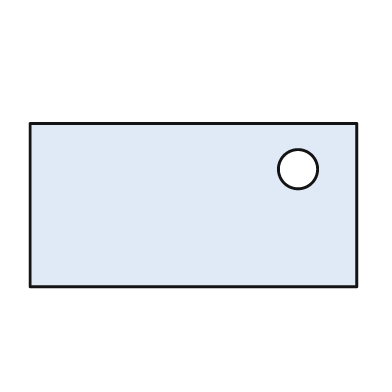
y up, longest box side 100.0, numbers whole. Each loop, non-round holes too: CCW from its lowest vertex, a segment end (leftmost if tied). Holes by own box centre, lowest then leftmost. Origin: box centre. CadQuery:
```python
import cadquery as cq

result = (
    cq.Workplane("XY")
    .moveTo(-50.0, -25.0)
    .lineTo(50.0, -25.0)
    .lineTo(50.0, 25.0)
    .lineTo(-50.0, 25.0)
    .close()
    .moveTo(32.0, 11.0)
    .circle(6.0)
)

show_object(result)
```